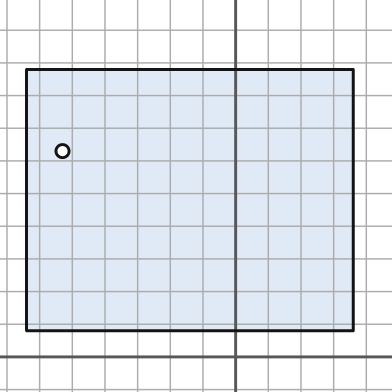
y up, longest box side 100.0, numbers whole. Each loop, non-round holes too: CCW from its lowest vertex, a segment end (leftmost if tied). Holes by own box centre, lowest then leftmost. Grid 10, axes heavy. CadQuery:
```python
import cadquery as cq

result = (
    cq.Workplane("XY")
    .moveTo(-64.0, 8.0)
    .lineTo(36.0, 8.0)
    .lineTo(36.0, 88.0)
    .lineTo(-64.0, 88.0)
    .close()
    .moveTo(-53.0, 63.0)
    .circle(2.0)
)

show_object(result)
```